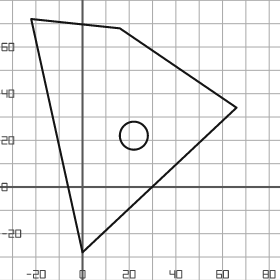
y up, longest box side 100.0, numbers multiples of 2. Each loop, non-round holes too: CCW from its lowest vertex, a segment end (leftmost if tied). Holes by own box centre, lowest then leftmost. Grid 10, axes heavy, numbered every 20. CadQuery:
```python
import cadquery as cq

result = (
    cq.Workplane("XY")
    .moveTo(0.0, -28.0)
    .lineTo(66.0, 34.0)
    .lineTo(16.0, 68.0)
    .lineTo(-22.0, 72.0)
    .close()
    .moveTo(22.0, 22.0)
    .circle(6.0)
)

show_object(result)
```